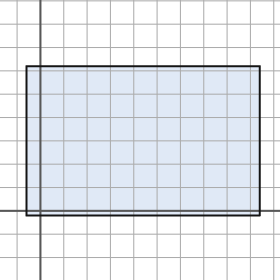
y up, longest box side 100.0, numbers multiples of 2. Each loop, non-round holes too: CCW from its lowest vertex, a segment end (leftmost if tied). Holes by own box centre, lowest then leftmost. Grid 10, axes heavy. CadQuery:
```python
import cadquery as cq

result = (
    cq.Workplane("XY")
    .moveTo(-6.0, -2.0)
    .lineTo(94.0, -2.0)
    .lineTo(94.0, 62.0)
    .lineTo(-6.0, 62.0)
    .close()
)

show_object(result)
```